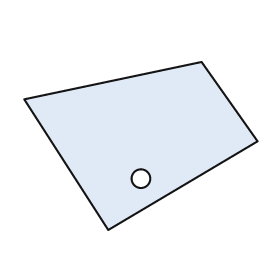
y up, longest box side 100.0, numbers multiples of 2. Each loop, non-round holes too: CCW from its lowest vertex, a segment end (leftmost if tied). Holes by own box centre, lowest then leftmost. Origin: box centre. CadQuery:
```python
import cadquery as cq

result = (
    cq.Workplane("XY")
    .moveTo(-14.0, -36.0)
    .lineTo(50.0, 2.0)
    .lineTo(26.0, 36.0)
    .lineTo(-50.0, 20.0)
    .close()
    .moveTo(0.0, -14.0)
    .circle(4.0)
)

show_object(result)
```